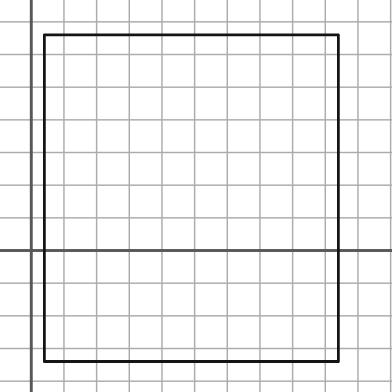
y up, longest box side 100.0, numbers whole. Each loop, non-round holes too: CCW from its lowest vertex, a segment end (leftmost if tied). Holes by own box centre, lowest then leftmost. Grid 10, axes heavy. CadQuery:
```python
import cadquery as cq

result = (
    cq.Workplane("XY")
    .moveTo(4.0, -34.0)
    .lineTo(94.0, -34.0)
    .lineTo(94.0, 66.0)
    .lineTo(4.0, 66.0)
    .close()
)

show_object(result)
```